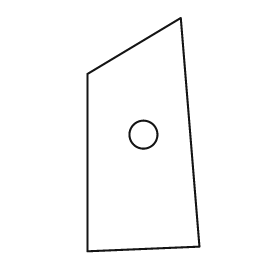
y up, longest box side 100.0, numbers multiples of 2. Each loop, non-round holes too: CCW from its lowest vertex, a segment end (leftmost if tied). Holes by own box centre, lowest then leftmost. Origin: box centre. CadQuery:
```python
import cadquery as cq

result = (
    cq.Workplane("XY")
    .moveTo(-24.0, -50.0)
    .lineTo(24.0, -48.0)
    .lineTo(16.0, 50.0)
    .lineTo(-24.0, 26.0)
    .close()
    .moveTo(0.0, 0.0)
    .circle(6.0)
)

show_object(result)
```